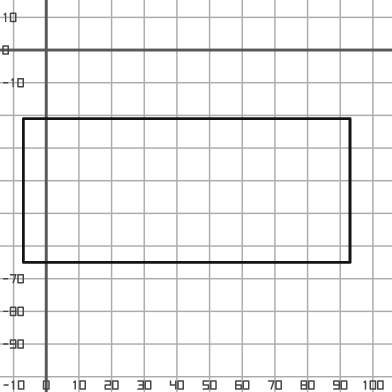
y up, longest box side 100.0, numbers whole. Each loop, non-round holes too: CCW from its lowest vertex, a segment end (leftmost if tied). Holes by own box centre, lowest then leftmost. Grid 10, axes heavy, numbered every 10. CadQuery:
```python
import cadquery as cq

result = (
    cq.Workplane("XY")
    .moveTo(-7.0, -65.0)
    .lineTo(93.0, -65.0)
    .lineTo(93.0, -21.0)
    .lineTo(-7.0, -21.0)
    .close()
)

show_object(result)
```